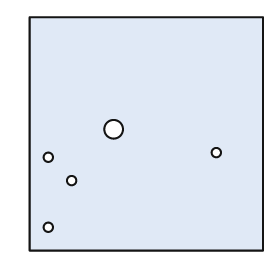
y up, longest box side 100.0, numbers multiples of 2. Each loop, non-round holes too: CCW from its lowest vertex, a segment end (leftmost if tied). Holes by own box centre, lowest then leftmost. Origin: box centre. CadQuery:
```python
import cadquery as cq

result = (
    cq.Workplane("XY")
    .moveTo(-50.0, -50.0)
    .lineTo(50.0, -50.0)
    .lineTo(50.0, 50.0)
    .lineTo(-50.0, 50.0)
    .close()
    .moveTo(-42.0, -40.0)
    .circle(2.0)
    .moveTo(-32.0, -20.0)
    .circle(2.0)
    .moveTo(-42.0, -10.0)
    .circle(2.0)
    .moveTo(30.0, -8.0)
    .circle(2.0)
    .moveTo(-14.0, 2.0)
    .circle(4.0)
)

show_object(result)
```